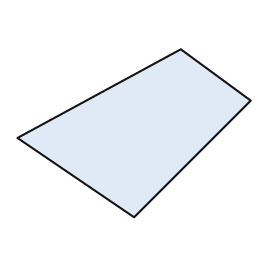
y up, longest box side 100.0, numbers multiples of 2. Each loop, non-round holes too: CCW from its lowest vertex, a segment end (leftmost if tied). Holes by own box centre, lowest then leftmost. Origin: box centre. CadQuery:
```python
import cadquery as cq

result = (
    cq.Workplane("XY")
    .moveTo(0.0, -36.0)
    .lineTo(50.0, 14.0)
    .lineTo(20.0, 36.0)
    .lineTo(-50.0, -2.0)
    .close()
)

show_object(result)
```